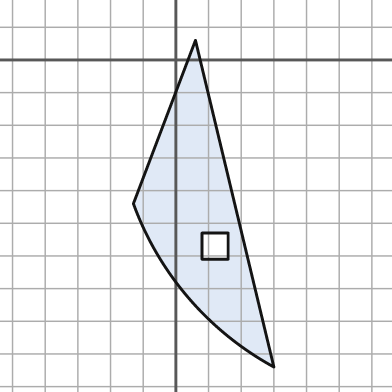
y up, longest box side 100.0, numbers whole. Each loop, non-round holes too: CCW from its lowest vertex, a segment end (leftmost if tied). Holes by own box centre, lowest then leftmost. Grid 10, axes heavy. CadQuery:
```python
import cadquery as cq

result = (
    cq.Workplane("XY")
    .moveTo(30.0, -94.0)
    .lineTo(6.0, 6.0)
    .lineTo(-13.0, -44.0)
    .threePointArc((4.0, -73.0), (30.0, -94.0))
    .close()
    .moveTo(8.0, -61.0)
    .lineTo(16.0, -61.0)
    .lineTo(16.0, -53.0)
    .lineTo(8.0, -53.0)
    .close()
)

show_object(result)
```